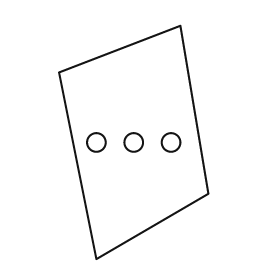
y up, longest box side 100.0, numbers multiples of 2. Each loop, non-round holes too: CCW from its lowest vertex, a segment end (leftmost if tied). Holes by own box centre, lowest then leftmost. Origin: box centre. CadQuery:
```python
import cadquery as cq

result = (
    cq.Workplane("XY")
    .moveTo(-16.0, -50.0)
    .lineTo(32.0, -22.0)
    .lineTo(20.0, 50.0)
    .lineTo(-32.0, 30.0)
    .close()
    .moveTo(-16.0, 0.0)
    .circle(4.0)
    .moveTo(0.0, 0.0)
    .circle(4.0)
    .moveTo(16.0, 0.0)
    .circle(4.0)
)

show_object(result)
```